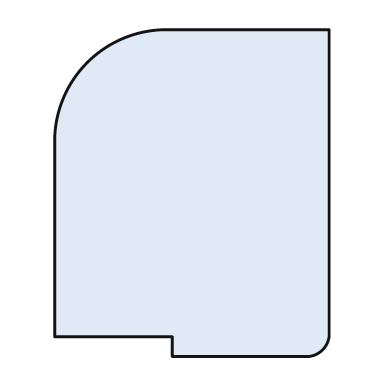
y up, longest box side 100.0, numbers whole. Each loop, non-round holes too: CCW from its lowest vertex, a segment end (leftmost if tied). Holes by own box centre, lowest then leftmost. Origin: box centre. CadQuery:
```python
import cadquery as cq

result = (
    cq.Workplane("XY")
    .moveTo(-6.0, -50.0)
    .lineTo(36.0, -50.0)
    .threePointArc((40.0, -48.0), (42.0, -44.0))
    .lineTo(42.0, 50.0)
    .lineTo(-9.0, 50.0)
    .threePointArc((-32.0, 40.0), (-42.0, 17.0))
    .lineTo(-42.0, -44.0)
    .lineTo(-6.0, -44.0)
    .close()
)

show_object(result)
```